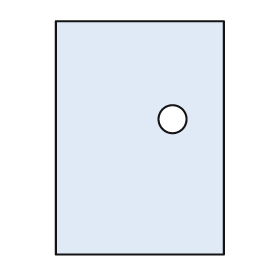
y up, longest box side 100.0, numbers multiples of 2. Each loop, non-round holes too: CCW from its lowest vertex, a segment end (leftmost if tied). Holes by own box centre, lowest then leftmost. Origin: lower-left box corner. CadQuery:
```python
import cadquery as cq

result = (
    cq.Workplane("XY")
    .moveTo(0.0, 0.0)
    .lineTo(72.0, 0.0)
    .lineTo(72.0, 100.0)
    .lineTo(0.0, 100.0)
    .close()
    .moveTo(50.0, 58.0)
    .circle(6.0)
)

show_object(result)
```